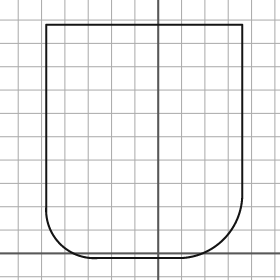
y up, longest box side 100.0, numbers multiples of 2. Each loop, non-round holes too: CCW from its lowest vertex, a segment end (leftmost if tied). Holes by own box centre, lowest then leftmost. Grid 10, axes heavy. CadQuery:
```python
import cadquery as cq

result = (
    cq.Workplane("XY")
    .moveTo(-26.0, -2.0)
    .lineTo(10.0, -2.0)
    .threePointArc((28.0, 6.0), (36.0, 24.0))
    .lineTo(36.0, 98.0)
    .lineTo(-48.0, 98.0)
    .lineTo(-48.0, 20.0)
    .threePointArc((-42.0, 4.0), (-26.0, -2.0))
    .close()
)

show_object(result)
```